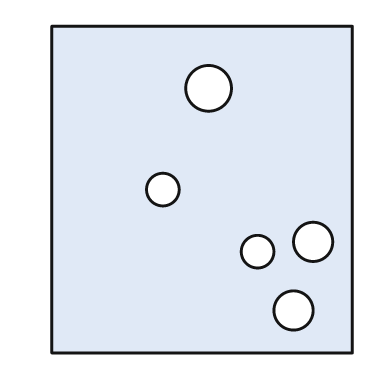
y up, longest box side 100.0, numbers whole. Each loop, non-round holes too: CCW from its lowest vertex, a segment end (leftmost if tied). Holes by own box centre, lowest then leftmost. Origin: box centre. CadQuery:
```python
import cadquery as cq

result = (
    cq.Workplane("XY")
    .moveTo(-46.0, -50.0)
    .lineTo(46.0, -50.0)
    .lineTo(46.0, 50.0)
    .lineTo(-46.0, 50.0)
    .close()
    .moveTo(28.0, -37.0)
    .circle(6.0)
    .moveTo(17.0, -19.0)
    .circle(5.0)
    .moveTo(34.0, -16.0)
    .circle(6.0)
    .moveTo(-12.0, 0.0)
    .circle(5.0)
    .moveTo(2.0, 31.0)
    .circle(7.0)
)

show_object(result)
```